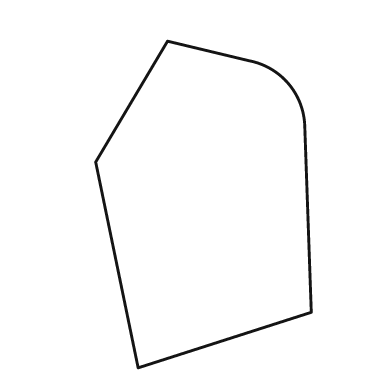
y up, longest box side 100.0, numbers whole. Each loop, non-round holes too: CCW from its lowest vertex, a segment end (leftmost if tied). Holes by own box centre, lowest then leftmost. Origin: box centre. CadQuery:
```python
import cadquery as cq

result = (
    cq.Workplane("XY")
    .moveTo(-20.0, -50.0)
    .lineTo(33.0, -33.0)
    .lineTo(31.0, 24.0)
    .threePointArc((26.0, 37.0), (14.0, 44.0))
    .lineTo(-11.0, 50.0)
    .lineTo(-33.0, 13.0)
    .close()
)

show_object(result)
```